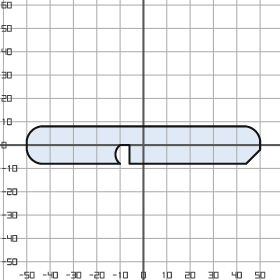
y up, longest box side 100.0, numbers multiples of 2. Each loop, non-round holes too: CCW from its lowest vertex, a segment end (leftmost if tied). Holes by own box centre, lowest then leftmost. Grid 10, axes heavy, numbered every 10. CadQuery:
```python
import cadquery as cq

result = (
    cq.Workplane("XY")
    .moveTo(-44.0, -8.0)
    .lineTo(-10.0, -8.0)
    .threePointArc((-12.0, -4.0), (-10.0, 0.0))
    .lineTo(-6.0, 0.0)
    .lineTo(-6.0, -8.0)
    .lineTo(44.0, -8.0)
    .lineTo(50.0, -2.0)
    .lineTo(50.0, 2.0)
    .threePointArc((48.0, 6.0), (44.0, 8.0))
    .lineTo(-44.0, 8.0)
    .threePointArc((-48.0, 6.0), (-50.0, 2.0))
    .lineTo(-50.0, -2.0)
    .threePointArc((-48.0, -6.0), (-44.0, -8.0))
    .close()
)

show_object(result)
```